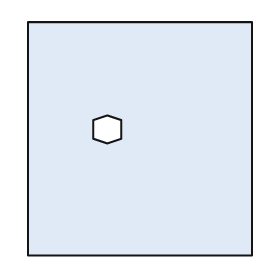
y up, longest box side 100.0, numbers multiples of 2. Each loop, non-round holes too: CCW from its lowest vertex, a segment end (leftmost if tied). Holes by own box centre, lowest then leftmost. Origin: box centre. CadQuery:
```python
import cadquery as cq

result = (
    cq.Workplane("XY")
    .moveTo(-48.0, -50.0)
    .lineTo(48.0, -50.0)
    .lineTo(48.0, 50.0)
    .lineTo(-48.0, 50.0)
    .close()
    .moveTo(-14.0, -2.0)
    .lineTo(-8.0, 0.0)
    .lineTo(-8.0, 8.0)
    .lineTo(-14.0, 10.0)
    .lineTo(-20.0, 8.0)
    .lineTo(-20.0, 0.0)
    .close()
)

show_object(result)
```